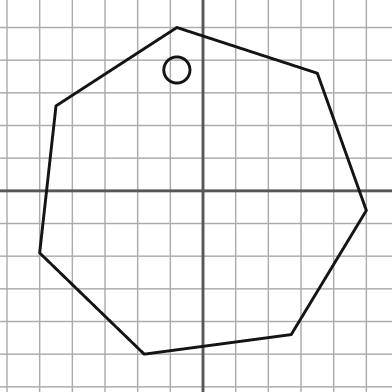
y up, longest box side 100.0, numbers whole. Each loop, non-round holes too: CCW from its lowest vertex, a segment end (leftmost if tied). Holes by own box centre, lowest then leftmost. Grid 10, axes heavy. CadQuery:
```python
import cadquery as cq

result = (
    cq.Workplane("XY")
    .moveTo(-18.0, -50.0)
    .lineTo(27.0, -44.0)
    .lineTo(50.0, -6.0)
    .lineTo(35.0, 36.0)
    .lineTo(-8.0, 50.0)
    .lineTo(-45.0, 26.0)
    .lineTo(-50.0, -19.0)
    .close()
    .moveTo(-8.0, 37.0)
    .circle(4.0)
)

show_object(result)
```